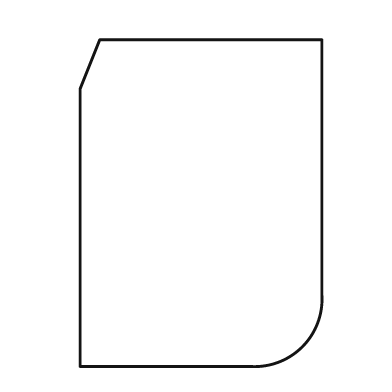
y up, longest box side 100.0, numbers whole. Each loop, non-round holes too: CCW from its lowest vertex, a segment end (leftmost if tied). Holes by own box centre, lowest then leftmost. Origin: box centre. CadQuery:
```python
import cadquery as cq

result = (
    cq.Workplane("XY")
    .moveTo(-37.0, -50.0)
    .lineTo(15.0, -50.0)
    .threePointArc((31.0, -44.0), (37.0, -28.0))
    .lineTo(37.0, 50.0)
    .lineTo(-31.0, 50.0)
    .lineTo(-37.0, 35.0)
    .close()
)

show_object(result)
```